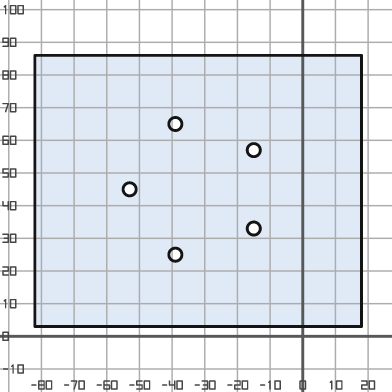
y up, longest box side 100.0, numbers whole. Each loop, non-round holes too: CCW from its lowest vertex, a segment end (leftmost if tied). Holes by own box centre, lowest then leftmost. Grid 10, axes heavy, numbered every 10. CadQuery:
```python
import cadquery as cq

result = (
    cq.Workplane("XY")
    .moveTo(-82.0, 3.0)
    .lineTo(18.0, 3.0)
    .lineTo(18.0, 86.0)
    .lineTo(-82.0, 86.0)
    .close()
    .moveTo(-39.0, 25.0)
    .circle(2.0)
    .moveTo(-15.0, 33.0)
    .circle(2.0)
    .moveTo(-53.0, 45.0)
    .circle(2.0)
    .moveTo(-15.0, 57.0)
    .circle(2.0)
    .moveTo(-39.0, 65.0)
    .circle(2.0)
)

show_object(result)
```